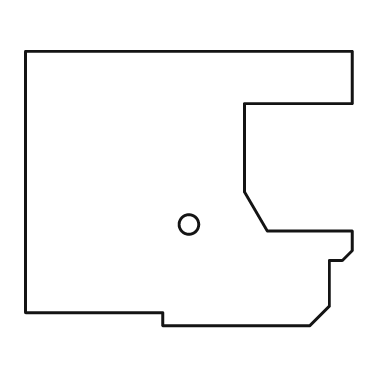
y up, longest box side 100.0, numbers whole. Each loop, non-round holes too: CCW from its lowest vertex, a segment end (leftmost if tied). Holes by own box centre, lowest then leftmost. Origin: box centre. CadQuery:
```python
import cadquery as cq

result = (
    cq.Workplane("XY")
    .moveTo(-8.0, -42.0)
    .lineTo(37.0, -42.0)
    .lineTo(43.0, -36.0)
    .lineTo(43.0, -22.0)
    .lineTo(47.0, -22.0)
    .lineTo(50.0, -19.0)
    .lineTo(50.0, -13.0)
    .lineTo(24.0, -13.0)
    .lineTo(17.0, -1.0)
    .lineTo(17.0, 26.0)
    .lineTo(50.0, 26.0)
    .lineTo(50.0, 42.0)
    .lineTo(-50.0, 42.0)
    .lineTo(-50.0, -38.0)
    .lineTo(-8.0, -38.0)
    .close()
    .moveTo(0.0, -11.0)
    .circle(3.0)
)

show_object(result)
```